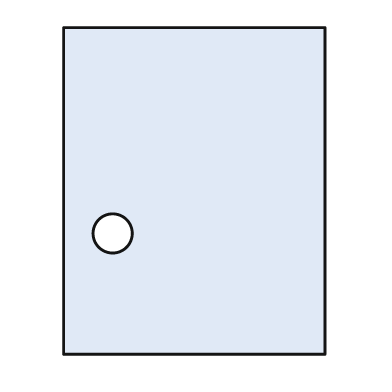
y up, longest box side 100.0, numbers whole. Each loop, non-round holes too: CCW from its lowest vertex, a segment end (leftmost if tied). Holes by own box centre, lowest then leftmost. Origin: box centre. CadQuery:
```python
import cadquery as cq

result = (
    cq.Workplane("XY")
    .moveTo(-40.0, -50.0)
    .lineTo(40.0, -50.0)
    .lineTo(40.0, 50.0)
    .lineTo(-40.0, 50.0)
    .close()
    .moveTo(-25.0, -13.0)
    .circle(6.0)
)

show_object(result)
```